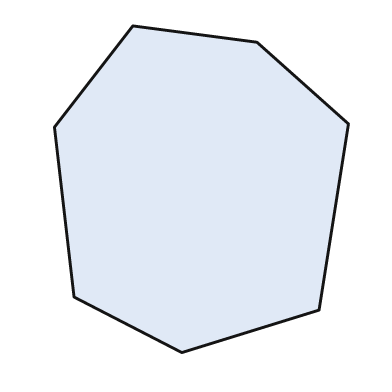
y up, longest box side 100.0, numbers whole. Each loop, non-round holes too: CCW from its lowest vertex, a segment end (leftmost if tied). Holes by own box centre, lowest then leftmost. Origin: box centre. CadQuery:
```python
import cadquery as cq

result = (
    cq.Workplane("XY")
    .moveTo(-6.0, -50.0)
    .lineTo(36.0, -37.0)
    .lineTo(45.0, 20.0)
    .lineTo(17.0, 45.0)
    .lineTo(-21.0, 50.0)
    .lineTo(-45.0, 19.0)
    .lineTo(-39.0, -33.0)
    .close()
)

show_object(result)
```